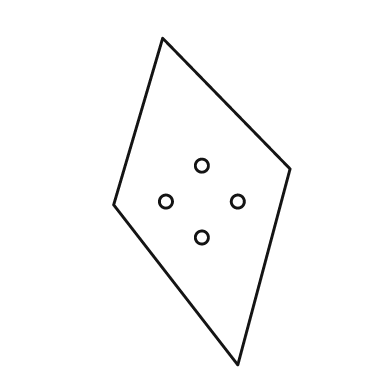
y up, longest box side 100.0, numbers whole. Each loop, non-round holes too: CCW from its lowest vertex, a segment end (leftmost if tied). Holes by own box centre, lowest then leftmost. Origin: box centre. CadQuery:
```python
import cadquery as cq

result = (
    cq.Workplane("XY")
    .moveTo(11.0, -50.0)
    .lineTo(27.0, 10.0)
    .lineTo(-12.0, 50.0)
    .lineTo(-27.0, -1.0)
    .close()
    .moveTo(0.0, -11.0)
    .circle(2.0)
    .moveTo(-11.0, 0.0)
    .circle(2.0)
    .moveTo(11.0, 0.0)
    .circle(2.0)
    .moveTo(0.0, 11.0)
    .circle(2.0)
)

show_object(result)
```